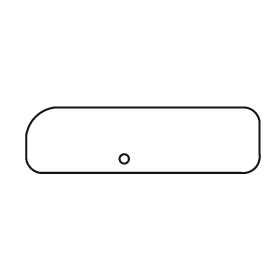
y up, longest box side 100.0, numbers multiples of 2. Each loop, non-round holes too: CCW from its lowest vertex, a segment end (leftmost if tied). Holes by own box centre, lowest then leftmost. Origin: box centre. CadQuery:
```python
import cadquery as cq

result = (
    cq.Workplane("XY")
    .moveTo(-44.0, -14.0)
    .lineTo(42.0, -14.0)
    .threePointArc((48.0, -12.0), (50.0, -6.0))
    .lineTo(50.0, 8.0)
    .threePointArc((48.0, 12.0), (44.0, 14.0))
    .lineTo(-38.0, 14.0)
    .threePointArc((-46.0, 10.0), (-50.0, 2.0))
    .lineTo(-50.0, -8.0)
    .threePointArc((-48.0, -12.0), (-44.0, -14.0))
    .close()
    .moveTo(-8.0, -8.0)
    .circle(2.0)
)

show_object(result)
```